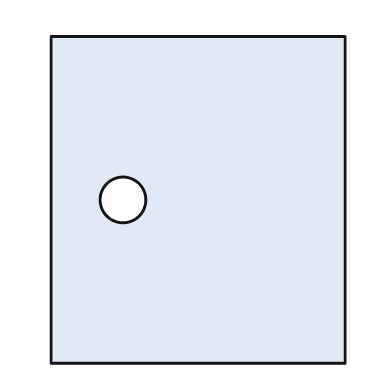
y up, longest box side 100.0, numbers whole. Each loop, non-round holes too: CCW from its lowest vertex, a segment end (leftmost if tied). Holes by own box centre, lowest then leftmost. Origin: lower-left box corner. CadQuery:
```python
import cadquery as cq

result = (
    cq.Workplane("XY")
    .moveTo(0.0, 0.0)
    .lineTo(90.0, 0.0)
    .lineTo(90.0, 100.0)
    .lineTo(0.0, 100.0)
    .close()
    .moveTo(22.0, 50.0)
    .circle(7.0)
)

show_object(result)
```